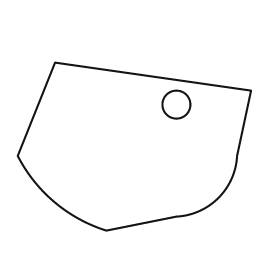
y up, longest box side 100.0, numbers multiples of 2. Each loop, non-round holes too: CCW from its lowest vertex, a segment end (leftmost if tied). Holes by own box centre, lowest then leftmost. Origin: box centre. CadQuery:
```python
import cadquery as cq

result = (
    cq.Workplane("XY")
    .moveTo(-12.0, -36.0)
    .lineTo(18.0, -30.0)
    .threePointArc((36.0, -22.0), (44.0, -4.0))
    .lineTo(50.0, 24.0)
    .lineTo(-34.0, 36.0)
    .lineTo(-50.0, -4.0)
    .threePointArc((-34.0, -24.0), (-12.0, -36.0))
    .close()
    .moveTo(18.0, 18.0)
    .circle(6.0)
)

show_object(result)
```